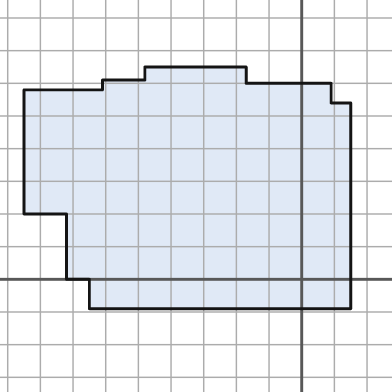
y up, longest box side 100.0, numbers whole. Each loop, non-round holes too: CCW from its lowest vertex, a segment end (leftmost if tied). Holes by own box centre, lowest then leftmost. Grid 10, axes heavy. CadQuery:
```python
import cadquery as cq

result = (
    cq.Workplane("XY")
    .moveTo(-65.0, -9.0)
    .lineTo(15.0, -9.0)
    .lineTo(15.0, 54.0)
    .lineTo(9.0, 54.0)
    .lineTo(9.0, 60.0)
    .lineTo(-17.0, 60.0)
    .lineTo(-17.0, 65.0)
    .lineTo(-48.0, 65.0)
    .lineTo(-48.0, 61.0)
    .lineTo(-61.0, 61.0)
    .lineTo(-61.0, 58.0)
    .lineTo(-85.0, 58.0)
    .lineTo(-85.0, 20.0)
    .lineTo(-72.0, 20.0)
    .lineTo(-72.0, 0.0)
    .lineTo(-65.0, 0.0)
    .close()
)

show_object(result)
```